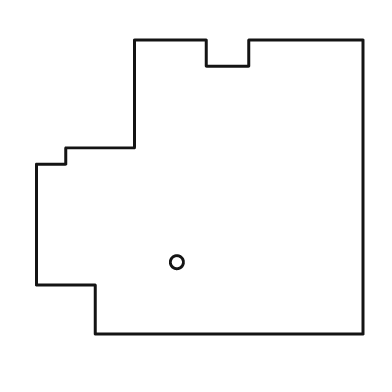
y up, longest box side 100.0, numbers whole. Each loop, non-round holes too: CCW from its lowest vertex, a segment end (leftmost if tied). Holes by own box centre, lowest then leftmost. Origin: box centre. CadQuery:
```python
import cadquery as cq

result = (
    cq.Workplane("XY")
    .moveTo(-32.0, -45.0)
    .lineTo(50.0, -45.0)
    .lineTo(50.0, 45.0)
    .lineTo(15.0, 45.0)
    .lineTo(15.0, 37.0)
    .lineTo(2.0, 37.0)
    .lineTo(2.0, 45.0)
    .lineTo(-20.0, 45.0)
    .lineTo(-20.0, 12.0)
    .lineTo(-41.0, 12.0)
    .lineTo(-41.0, 7.0)
    .lineTo(-50.0, 7.0)
    .lineTo(-50.0, -30.0)
    .lineTo(-32.0, -30.0)
    .close()
    .moveTo(-7.0, -23.0)
    .circle(2.0)
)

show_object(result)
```